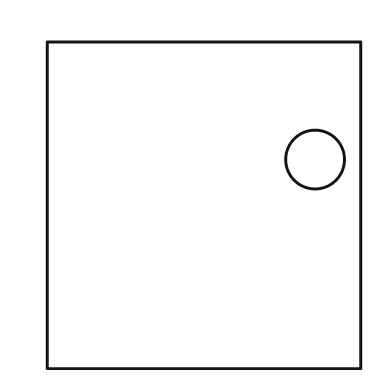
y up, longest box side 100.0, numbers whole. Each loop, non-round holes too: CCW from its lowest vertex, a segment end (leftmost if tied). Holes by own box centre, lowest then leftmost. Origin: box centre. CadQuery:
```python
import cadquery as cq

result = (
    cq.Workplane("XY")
    .moveTo(-48.0, -50.0)
    .lineTo(48.0, -50.0)
    .lineTo(48.0, 50.0)
    .lineTo(-48.0, 50.0)
    .close()
    .moveTo(34.0, 14.0)
    .circle(9.0)
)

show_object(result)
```